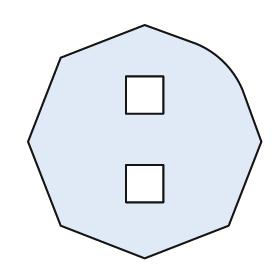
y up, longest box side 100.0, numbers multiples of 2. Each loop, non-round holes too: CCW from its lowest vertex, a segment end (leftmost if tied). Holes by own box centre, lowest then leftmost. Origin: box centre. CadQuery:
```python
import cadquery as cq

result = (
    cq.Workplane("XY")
    .moveTo(0.0, -50.0)
    .lineTo(36.0, -36.0)
    .lineTo(50.0, 0.0)
    .lineTo(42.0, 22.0)
    .threePointArc((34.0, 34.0), (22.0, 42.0))
    .lineTo(0.0, 50.0)
    .lineTo(-36.0, 36.0)
    .lineTo(-50.0, 0.0)
    .lineTo(-36.0, -36.0)
    .close()
    .moveTo(-8.0, -26.0)
    .lineTo(8.0, -26.0)
    .lineTo(8.0, -10.0)
    .lineTo(-8.0, -10.0)
    .close()
    .moveTo(-8.0, 12.0)
    .lineTo(8.0, 12.0)
    .lineTo(8.0, 28.0)
    .lineTo(-8.0, 28.0)
    .close()
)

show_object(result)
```